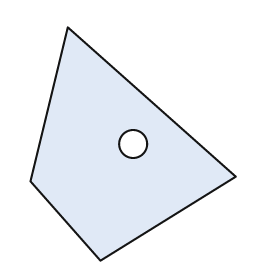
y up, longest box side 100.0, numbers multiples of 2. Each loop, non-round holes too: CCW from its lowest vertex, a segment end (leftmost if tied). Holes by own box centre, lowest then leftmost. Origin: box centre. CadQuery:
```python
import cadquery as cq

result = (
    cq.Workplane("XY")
    .moveTo(-14.0, -50.0)
    .lineTo(44.0, -14.0)
    .lineTo(-28.0, 50.0)
    .lineTo(-44.0, -16.0)
    .close()
    .moveTo(0.0, 0.0)
    .circle(6.0)
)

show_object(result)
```